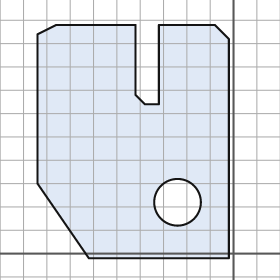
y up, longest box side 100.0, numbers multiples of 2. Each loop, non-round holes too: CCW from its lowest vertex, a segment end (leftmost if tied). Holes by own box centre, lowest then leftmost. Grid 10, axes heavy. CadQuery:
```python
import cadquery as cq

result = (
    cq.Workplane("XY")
    .moveTo(-62.0, -2.0)
    .lineTo(-2.0, -2.0)
    .lineTo(-2.0, 92.0)
    .lineTo(-8.0, 98.0)
    .lineTo(-32.0, 98.0)
    .lineTo(-32.0, 64.0)
    .lineTo(-38.0, 64.0)
    .lineTo(-42.0, 68.0)
    .lineTo(-42.0, 98.0)
    .lineTo(-76.0, 98.0)
    .lineTo(-84.0, 94.0)
    .lineTo(-84.0, 30.0)
    .close()
    .moveTo(-24.0, 22.0)
    .circle(10.0)
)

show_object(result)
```